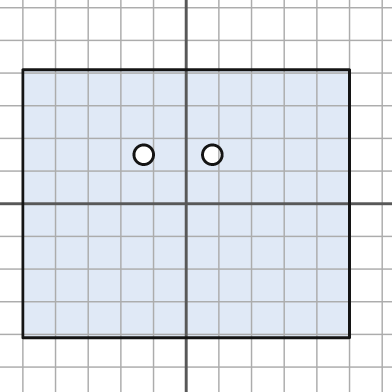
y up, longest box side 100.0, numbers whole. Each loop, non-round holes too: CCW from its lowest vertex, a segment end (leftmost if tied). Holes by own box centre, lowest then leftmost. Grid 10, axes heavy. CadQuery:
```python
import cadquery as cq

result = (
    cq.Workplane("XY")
    .moveTo(-50.0, -41.0)
    .lineTo(50.0, -41.0)
    .lineTo(50.0, 41.0)
    .lineTo(-50.0, 41.0)
    .close()
    .moveTo(-13.0, 15.0)
    .circle(3.0)
    .moveTo(8.0, 15.0)
    .circle(3.0)
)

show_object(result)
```